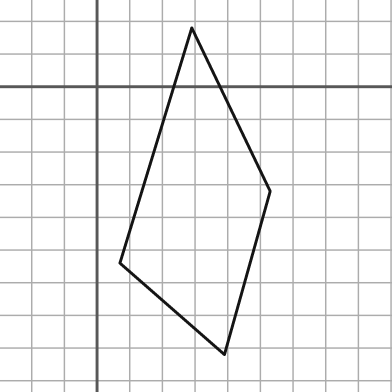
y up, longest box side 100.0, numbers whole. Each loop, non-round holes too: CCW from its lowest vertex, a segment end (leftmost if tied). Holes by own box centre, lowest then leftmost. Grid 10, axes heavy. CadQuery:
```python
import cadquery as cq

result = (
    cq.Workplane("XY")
    .moveTo(39.0, -82.0)
    .lineTo(53.0, -32.0)
    .lineTo(29.0, 18.0)
    .lineTo(7.0, -54.0)
    .close()
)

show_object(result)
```